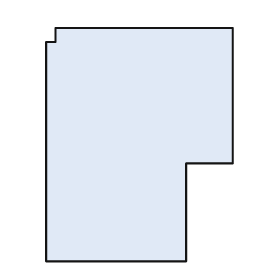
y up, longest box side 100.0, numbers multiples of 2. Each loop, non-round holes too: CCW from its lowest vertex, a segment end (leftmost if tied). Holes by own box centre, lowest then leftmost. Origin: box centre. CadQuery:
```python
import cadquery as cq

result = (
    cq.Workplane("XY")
    .moveTo(-40.0, -50.0)
    .lineTo(20.0, -50.0)
    .lineTo(20.0, -8.0)
    .lineTo(40.0, -8.0)
    .lineTo(40.0, 50.0)
    .lineTo(-36.0, 50.0)
    .lineTo(-36.0, 44.0)
    .lineTo(-40.0, 44.0)
    .close()
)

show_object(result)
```